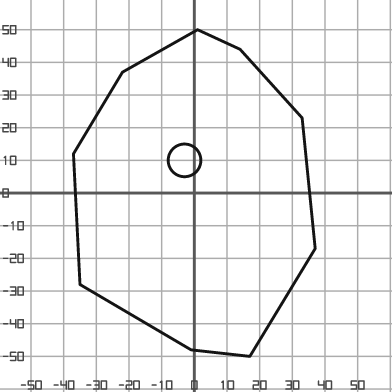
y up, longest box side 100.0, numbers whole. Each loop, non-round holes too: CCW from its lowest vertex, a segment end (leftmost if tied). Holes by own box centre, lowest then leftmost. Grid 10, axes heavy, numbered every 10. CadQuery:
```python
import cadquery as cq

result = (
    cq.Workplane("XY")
    .moveTo(17.0, -50.0)
    .lineTo(37.0, -17.0)
    .lineTo(33.0, 23.0)
    .lineTo(14.0, 44.0)
    .lineTo(1.0, 50.0)
    .lineTo(-22.0, 37.0)
    .lineTo(-37.0, 12.0)
    .lineTo(-35.0, -28.0)
    .lineTo(-1.0, -48.0)
    .close()
    .moveTo(-3.0, 10.0)
    .circle(5.0)
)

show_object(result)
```